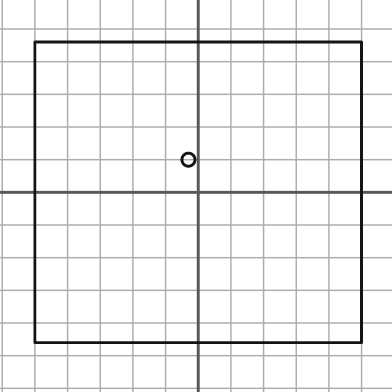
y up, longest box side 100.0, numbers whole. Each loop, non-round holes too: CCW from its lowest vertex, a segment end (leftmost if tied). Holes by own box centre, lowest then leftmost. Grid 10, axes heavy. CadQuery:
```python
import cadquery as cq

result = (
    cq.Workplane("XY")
    .moveTo(-50.0, -46.0)
    .lineTo(50.0, -46.0)
    .lineTo(50.0, 46.0)
    .lineTo(-50.0, 46.0)
    .close()
    .moveTo(-3.0, 10.0)
    .circle(2.0)
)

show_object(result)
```